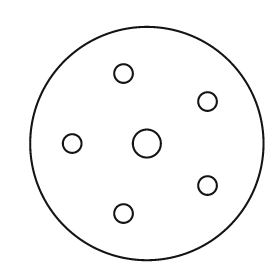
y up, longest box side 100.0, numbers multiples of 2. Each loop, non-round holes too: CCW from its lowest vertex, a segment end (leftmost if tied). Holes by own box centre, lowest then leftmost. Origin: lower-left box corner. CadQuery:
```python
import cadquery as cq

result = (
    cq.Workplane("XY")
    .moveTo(50.0, 50.0)
    .circle(50.0)
    .moveTo(40.0, 20.0)
    .circle(4.0)
    .moveTo(76.0, 32.0)
    .circle(4.0)
    .moveTo(18.0, 50.0)
    .circle(4.0)
    .moveTo(50.0, 50.0)
    .circle(6.0)
    .moveTo(76.0, 68.0)
    .circle(4.0)
    .moveTo(40.0, 80.0)
    .circle(4.0)
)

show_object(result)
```